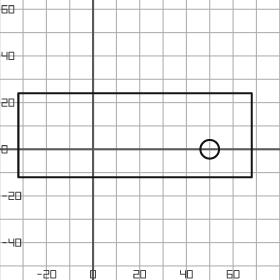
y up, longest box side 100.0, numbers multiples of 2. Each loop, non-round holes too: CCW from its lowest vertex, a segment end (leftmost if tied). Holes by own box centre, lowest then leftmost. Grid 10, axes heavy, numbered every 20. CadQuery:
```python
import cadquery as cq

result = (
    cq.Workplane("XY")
    .moveTo(-32.0, -12.0)
    .lineTo(68.0, -12.0)
    .lineTo(68.0, 24.0)
    .lineTo(-32.0, 24.0)
    .close()
    .moveTo(50.0, 0.0)
    .circle(4.0)
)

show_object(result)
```